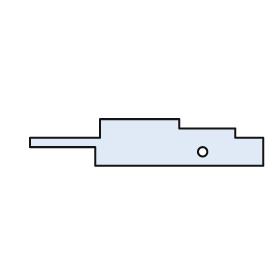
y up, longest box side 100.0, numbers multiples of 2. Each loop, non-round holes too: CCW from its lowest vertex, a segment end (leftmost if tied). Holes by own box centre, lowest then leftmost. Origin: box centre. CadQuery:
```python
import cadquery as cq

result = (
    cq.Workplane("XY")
    .moveTo(-22.0, -10.0)
    .lineTo(50.0, -10.0)
    .lineTo(50.0, 2.0)
    .lineTo(38.0, 2.0)
    .lineTo(38.0, 6.0)
    .lineTo(14.0, 6.0)
    .lineTo(14.0, 10.0)
    .lineTo(-20.0, 10.0)
    .lineTo(-20.0, 2.0)
    .lineTo(-50.0, 2.0)
    .lineTo(-50.0, -2.0)
    .lineTo(-22.0, -2.0)
    .close()
    .moveTo(24.0, -4.0)
    .circle(2.0)
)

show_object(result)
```